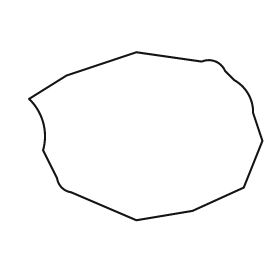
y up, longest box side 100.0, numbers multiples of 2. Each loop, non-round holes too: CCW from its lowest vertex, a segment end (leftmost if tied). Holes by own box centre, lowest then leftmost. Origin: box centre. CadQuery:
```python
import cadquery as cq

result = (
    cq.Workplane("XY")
    .moveTo(-4.0, -36.0)
    .lineTo(20.0, -32.0)
    .lineTo(42.0, -22.0)
    .lineTo(50.0, -2.0)
    .lineTo(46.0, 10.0)
    .threePointArc((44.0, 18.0), (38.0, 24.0))
    .lineTo(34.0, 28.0)
    .threePointArc((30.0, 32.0), (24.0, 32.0))
    .lineTo(-4.0, 36.0)
    .lineTo(-34.0, 26.0)
    .lineTo(-50.0, 16.0)
    .threePointArc((-44.0, 6.0), (-44.0, -6.0))
    .lineTo(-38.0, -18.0)
    .threePointArc((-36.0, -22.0), (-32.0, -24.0))
    .close()
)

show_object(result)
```